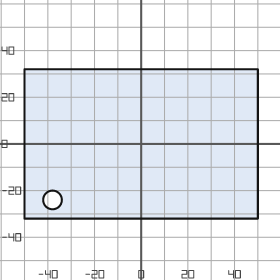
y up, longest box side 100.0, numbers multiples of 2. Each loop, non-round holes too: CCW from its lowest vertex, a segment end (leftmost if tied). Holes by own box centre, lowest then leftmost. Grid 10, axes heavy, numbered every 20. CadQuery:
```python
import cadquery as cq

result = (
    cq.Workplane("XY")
    .moveTo(-50.0, -32.0)
    .lineTo(50.0, -32.0)
    .lineTo(50.0, 32.0)
    .lineTo(-50.0, 32.0)
    .close()
    .moveTo(-38.0, -24.0)
    .circle(4.0)
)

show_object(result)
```